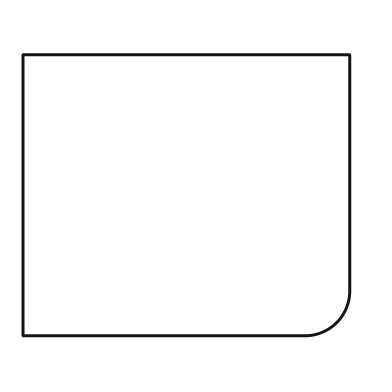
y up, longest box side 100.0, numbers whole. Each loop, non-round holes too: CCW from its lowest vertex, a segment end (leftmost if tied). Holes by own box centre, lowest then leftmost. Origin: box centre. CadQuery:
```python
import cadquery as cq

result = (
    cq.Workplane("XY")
    .moveTo(-50.0, -43.0)
    .lineTo(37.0, -43.0)
    .threePointArc((46.0, -39.0), (50.0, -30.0))
    .lineTo(50.0, 43.0)
    .lineTo(-50.0, 43.0)
    .close()
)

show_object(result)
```